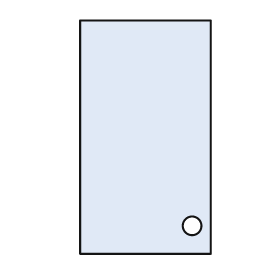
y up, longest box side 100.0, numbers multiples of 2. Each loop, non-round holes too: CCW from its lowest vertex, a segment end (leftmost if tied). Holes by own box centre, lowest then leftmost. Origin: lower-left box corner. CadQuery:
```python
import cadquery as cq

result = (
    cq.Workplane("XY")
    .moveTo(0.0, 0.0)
    .lineTo(56.0, 0.0)
    .lineTo(56.0, 100.0)
    .lineTo(0.0, 100.0)
    .close()
    .moveTo(48.0, 12.0)
    .circle(4.0)
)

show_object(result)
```